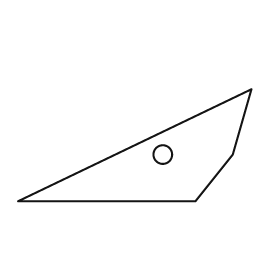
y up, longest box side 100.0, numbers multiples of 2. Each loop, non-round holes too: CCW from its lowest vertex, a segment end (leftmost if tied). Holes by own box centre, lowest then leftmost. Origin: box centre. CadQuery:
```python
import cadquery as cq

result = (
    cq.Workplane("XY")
    .moveTo(-50.0, -24.0)
    .lineTo(26.0, -24.0)
    .lineTo(42.0, -4.0)
    .lineTo(50.0, 24.0)
    .close()
    .moveTo(12.0, -4.0)
    .circle(4.0)
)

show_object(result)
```